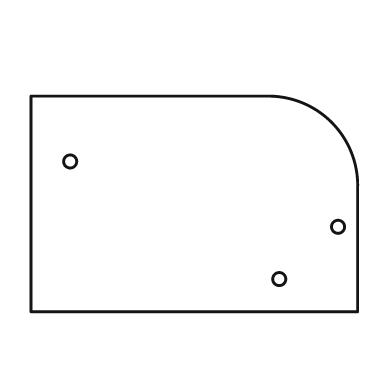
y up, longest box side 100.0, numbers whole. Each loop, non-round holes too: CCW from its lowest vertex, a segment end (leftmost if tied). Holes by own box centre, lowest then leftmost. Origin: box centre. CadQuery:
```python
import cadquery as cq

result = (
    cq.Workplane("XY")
    .moveTo(-50.0, -33.0)
    .lineTo(50.0, -33.0)
    .lineTo(50.0, 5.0)
    .threePointArc((42.0, 25.0), (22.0, 33.0))
    .lineTo(-50.0, 33.0)
    .close()
    .moveTo(26.0, -23.0)
    .circle(2.0)
    .moveTo(44.0, -7.0)
    .circle(2.0)
    .moveTo(-38.0, 13.0)
    .circle(2.0)
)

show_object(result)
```